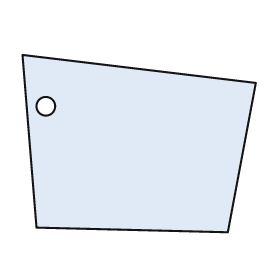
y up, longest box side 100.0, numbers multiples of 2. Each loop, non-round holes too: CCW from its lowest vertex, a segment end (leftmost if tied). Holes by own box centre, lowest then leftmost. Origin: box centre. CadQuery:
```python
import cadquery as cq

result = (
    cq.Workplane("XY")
    .moveTo(38.0, -38.0)
    .lineTo(50.0, 26.0)
    .lineTo(-50.0, 38.0)
    .lineTo(-44.0, -36.0)
    .close()
    .moveTo(-40.0, 16.0)
    .circle(4.0)
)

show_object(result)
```